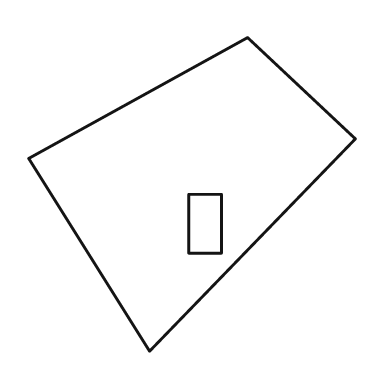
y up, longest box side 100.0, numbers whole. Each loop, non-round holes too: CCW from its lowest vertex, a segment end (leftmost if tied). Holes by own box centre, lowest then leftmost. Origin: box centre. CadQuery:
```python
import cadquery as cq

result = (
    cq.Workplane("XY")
    .moveTo(-13.0, -48.0)
    .lineTo(50.0, 17.0)
    .lineTo(17.0, 48.0)
    .lineTo(-50.0, 11.0)
    .close()
    .moveTo(-1.0, -18.0)
    .lineTo(9.0, -18.0)
    .lineTo(9.0, 0.0)
    .lineTo(-1.0, 0.0)
    .close()
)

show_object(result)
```